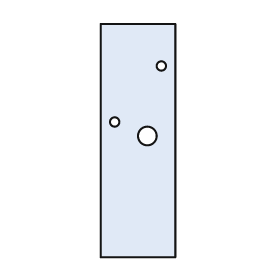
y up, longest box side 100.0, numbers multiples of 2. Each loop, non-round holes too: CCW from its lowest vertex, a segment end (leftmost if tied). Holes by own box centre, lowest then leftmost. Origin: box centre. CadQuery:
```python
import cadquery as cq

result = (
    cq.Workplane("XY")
    .moveTo(-16.0, -50.0)
    .lineTo(16.0, -50.0)
    .lineTo(16.0, 50.0)
    .lineTo(-16.0, 50.0)
    .close()
    .moveTo(4.0, 2.0)
    .circle(4.0)
    .moveTo(-10.0, 8.0)
    .circle(2.0)
    .moveTo(10.0, 32.0)
    .circle(2.0)
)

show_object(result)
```